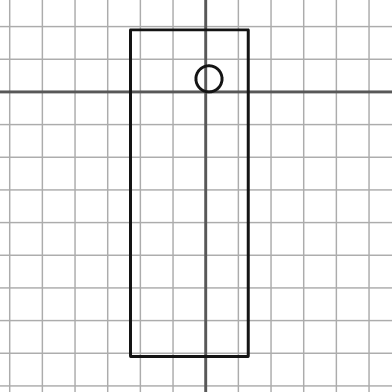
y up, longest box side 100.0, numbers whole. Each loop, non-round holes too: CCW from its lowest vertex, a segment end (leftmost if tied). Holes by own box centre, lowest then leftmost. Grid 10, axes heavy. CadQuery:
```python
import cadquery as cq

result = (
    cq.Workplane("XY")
    .moveTo(-23.0, -81.0)
    .lineTo(13.0, -81.0)
    .lineTo(13.0, 19.0)
    .lineTo(-23.0, 19.0)
    .close()
    .moveTo(1.0, 4.0)
    .circle(4.0)
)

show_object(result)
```